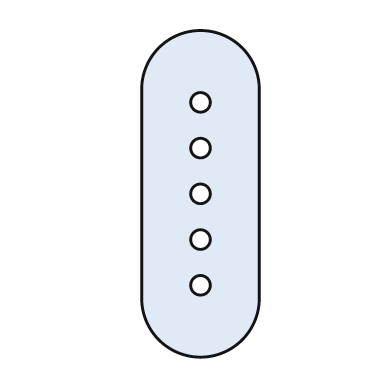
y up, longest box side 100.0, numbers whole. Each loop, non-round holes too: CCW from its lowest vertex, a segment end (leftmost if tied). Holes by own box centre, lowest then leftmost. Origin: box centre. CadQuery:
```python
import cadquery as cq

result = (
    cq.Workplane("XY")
    .moveTo(-18.0, -32.0)
    .threePointArc((0.0, -50.0), (18.0, -32.0))
    .lineTo(18.0, 32.0)
    .threePointArc((0.0, 50.0), (-18.0, 32.0))
    .close()
    .moveTo(0.0, -28.0)
    .circle(3.0)
    .moveTo(0.0, -14.0)
    .circle(3.0)
    .moveTo(0.0, 0.0)
    .circle(3.0)
    .moveTo(0.0, 14.0)
    .circle(3.0)
    .moveTo(0.0, 28.0)
    .circle(3.0)
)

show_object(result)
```